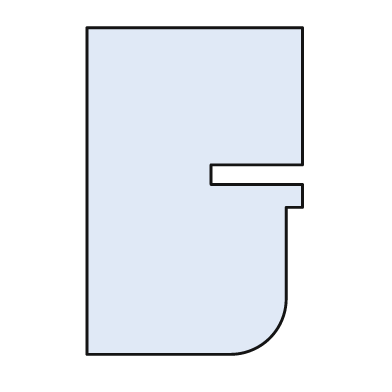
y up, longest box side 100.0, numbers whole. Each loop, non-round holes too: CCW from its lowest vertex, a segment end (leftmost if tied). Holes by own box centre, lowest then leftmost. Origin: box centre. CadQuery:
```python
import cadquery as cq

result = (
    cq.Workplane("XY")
    .moveTo(-33.0, -50.0)
    .lineTo(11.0, -50.0)
    .threePointArc((23.0, -45.0), (28.0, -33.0))
    .lineTo(28.0, -5.0)
    .lineTo(33.0, -5.0)
    .lineTo(33.0, 2.0)
    .lineTo(5.0, 2.0)
    .lineTo(5.0, 8.0)
    .lineTo(33.0, 8.0)
    .lineTo(33.0, 50.0)
    .lineTo(-33.0, 50.0)
    .close()
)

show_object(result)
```